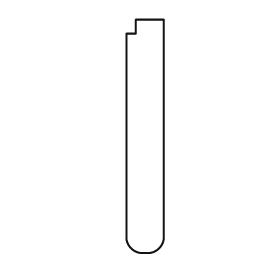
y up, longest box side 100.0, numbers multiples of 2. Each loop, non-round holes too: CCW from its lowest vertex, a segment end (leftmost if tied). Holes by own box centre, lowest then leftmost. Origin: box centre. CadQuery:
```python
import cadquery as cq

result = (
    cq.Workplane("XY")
    .moveTo(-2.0, -50.0)
    .lineTo(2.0, -50.0)
    .threePointArc((6.0, -48.0), (8.0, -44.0))
    .lineTo(8.0, 50.0)
    .lineTo(-4.0, 50.0)
    .lineTo(-4.0, 44.0)
    .lineTo(-8.0, 44.0)
    .lineTo(-8.0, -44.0)
    .threePointArc((-6.0, -48.0), (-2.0, -50.0))
    .close()
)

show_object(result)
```